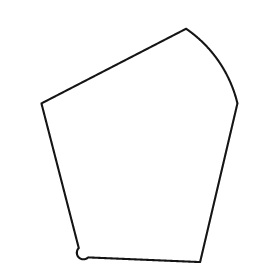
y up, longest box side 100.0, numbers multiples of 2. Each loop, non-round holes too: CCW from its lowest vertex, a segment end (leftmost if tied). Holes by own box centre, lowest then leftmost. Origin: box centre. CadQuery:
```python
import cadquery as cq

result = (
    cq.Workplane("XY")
    .moveTo(26.0, -50.0)
    .lineTo(42.0, 18.0)
    .threePointArc((34.0, 36.0), (20.0, 50.0))
    .lineTo(-42.0, 18.0)
    .lineTo(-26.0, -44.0)
    .threePointArc((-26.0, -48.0), (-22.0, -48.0))
    .close()
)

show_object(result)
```